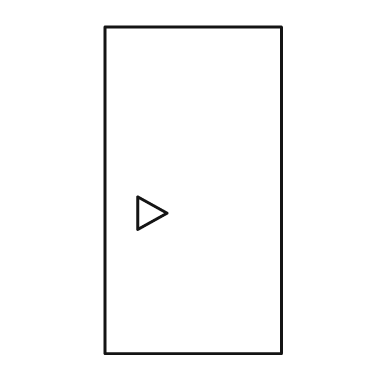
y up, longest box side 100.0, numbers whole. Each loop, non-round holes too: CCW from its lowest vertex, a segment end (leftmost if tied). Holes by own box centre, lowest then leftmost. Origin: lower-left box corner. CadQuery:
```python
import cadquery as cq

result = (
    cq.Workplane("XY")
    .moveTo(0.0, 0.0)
    .lineTo(54.0, 0.0)
    .lineTo(54.0, 100.0)
    .lineTo(0.0, 100.0)
    .close()
    .moveTo(10.0, 38.0)
    .lineTo(19.0, 43.0)
    .lineTo(10.0, 48.0)
    .close()
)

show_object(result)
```